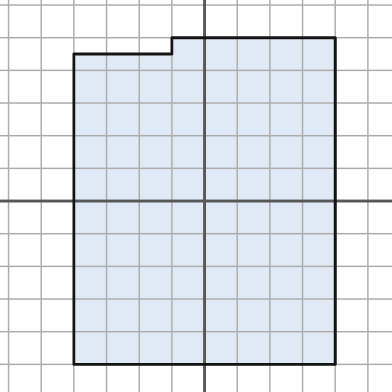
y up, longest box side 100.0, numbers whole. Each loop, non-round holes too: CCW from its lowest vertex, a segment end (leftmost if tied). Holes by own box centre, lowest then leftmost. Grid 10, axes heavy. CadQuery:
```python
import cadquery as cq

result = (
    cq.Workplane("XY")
    .moveTo(-40.0, -50.0)
    .lineTo(40.0, -50.0)
    .lineTo(40.0, 50.0)
    .lineTo(-10.0, 50.0)
    .lineTo(-10.0, 45.0)
    .lineTo(-40.0, 45.0)
    .close()
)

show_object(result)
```